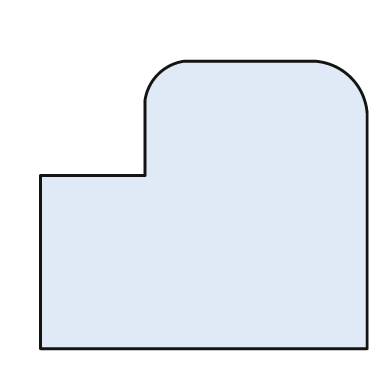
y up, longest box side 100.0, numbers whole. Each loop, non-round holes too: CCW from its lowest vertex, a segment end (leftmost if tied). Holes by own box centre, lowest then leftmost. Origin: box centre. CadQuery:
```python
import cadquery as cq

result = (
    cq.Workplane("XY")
    .moveTo(-50.0, -44.0)
    .lineTo(50.0, -44.0)
    .lineTo(50.0, 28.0)
    .threePointArc((45.0, 39.0), (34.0, 44.0))
    .lineTo(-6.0, 44.0)
    .threePointArc((-14.0, 40.0), (-18.0, 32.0))
    .lineTo(-18.0, 9.0)
    .lineTo(-50.0, 9.0)
    .close()
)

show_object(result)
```